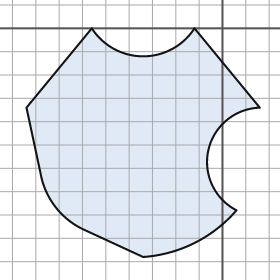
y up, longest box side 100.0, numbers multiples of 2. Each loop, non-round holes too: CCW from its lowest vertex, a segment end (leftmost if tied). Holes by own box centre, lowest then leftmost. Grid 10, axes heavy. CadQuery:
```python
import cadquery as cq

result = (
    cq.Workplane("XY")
    .moveTo(-34.0, -98.0)
    .threePointArc((-12.0, -92.0), (6.0, -78.0))
    .threePointArc((-6.0, -52.0), (16.0, -34.0))
    .lineTo(-12.0, 0.0)
    .threePointArc((-34.0, -12.0), (-56.0, 0.0))
    .lineTo(-84.0, -34.0)
    .lineTo(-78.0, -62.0)
    .threePointArc((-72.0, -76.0), (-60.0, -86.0))
    .close()
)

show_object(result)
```